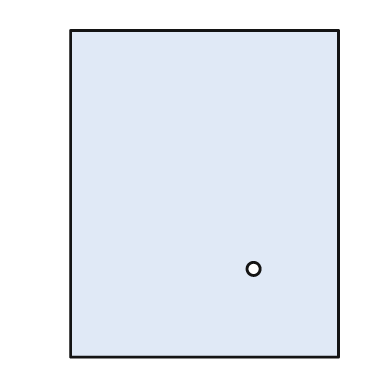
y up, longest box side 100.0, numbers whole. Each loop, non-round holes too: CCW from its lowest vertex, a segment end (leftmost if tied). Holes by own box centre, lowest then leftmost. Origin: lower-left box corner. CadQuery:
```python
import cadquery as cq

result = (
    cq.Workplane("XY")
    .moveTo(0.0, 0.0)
    .lineTo(82.0, 0.0)
    .lineTo(82.0, 100.0)
    .lineTo(0.0, 100.0)
    .close()
    .moveTo(56.0, 27.0)
    .circle(2.0)
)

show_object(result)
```